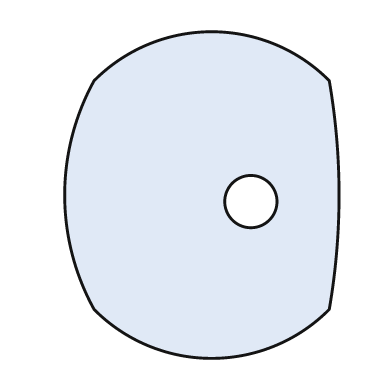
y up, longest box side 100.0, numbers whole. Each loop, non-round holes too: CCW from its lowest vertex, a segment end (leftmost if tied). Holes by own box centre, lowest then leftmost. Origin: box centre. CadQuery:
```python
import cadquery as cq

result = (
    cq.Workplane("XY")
    .moveTo(-33.0, -35.0)
    .threePointArc((3.0, -50.0), (39.0, -35.0))
    .threePointArc((42.0, 0.0), (39.0, 35.0))
    .threePointArc((3.0, 50.0), (-33.0, 35.0))
    .threePointArc((-42.0, 0.0), (-33.0, -35.0))
    .close()
    .moveTo(15.0, -2.0)
    .circle(8.0)
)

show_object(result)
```